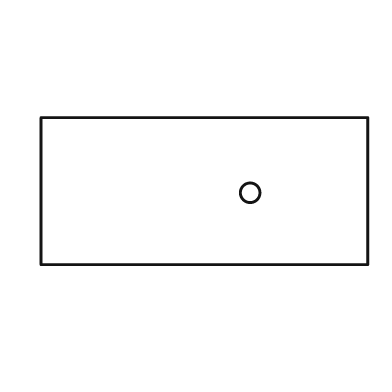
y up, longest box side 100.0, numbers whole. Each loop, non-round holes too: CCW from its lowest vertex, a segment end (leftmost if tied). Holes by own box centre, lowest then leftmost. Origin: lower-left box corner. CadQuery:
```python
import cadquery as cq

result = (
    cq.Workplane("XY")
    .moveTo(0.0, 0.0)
    .lineTo(100.0, 0.0)
    .lineTo(100.0, 45.0)
    .lineTo(0.0, 45.0)
    .close()
    .moveTo(64.0, 22.0)
    .circle(3.0)
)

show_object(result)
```